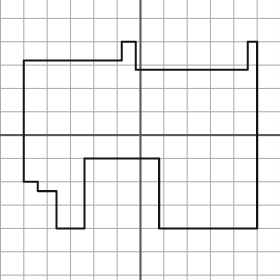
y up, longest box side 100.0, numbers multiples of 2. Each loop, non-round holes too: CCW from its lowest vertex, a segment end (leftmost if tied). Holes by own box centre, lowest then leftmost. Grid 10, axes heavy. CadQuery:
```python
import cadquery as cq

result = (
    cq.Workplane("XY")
    .moveTo(-36.0, -40.0)
    .lineTo(-24.0, -40.0)
    .lineTo(-24.0, -10.0)
    .lineTo(8.0, -10.0)
    .lineTo(8.0, -40.0)
    .lineTo(50.0, -40.0)
    .lineTo(50.0, 40.0)
    .lineTo(46.0, 40.0)
    .lineTo(46.0, 28.0)
    .lineTo(-2.0, 28.0)
    .lineTo(-2.0, 40.0)
    .lineTo(-8.0, 40.0)
    .lineTo(-8.0, 32.0)
    .lineTo(-50.0, 32.0)
    .lineTo(-50.0, -20.0)
    .lineTo(-44.0, -20.0)
    .lineTo(-44.0, -24.0)
    .lineTo(-36.0, -24.0)
    .close()
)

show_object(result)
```